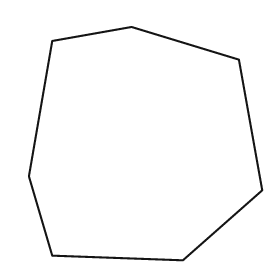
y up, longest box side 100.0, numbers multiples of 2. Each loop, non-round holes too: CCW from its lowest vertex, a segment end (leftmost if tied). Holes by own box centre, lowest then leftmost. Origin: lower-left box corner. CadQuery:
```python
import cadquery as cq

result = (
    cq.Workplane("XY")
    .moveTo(66.0, 0.0)
    .lineTo(100.0, 30.0)
    .lineTo(90.0, 86.0)
    .lineTo(44.0, 100.0)
    .lineTo(10.0, 94.0)
    .lineTo(0.0, 36.0)
    .lineTo(10.0, 2.0)
    .close()
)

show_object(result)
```